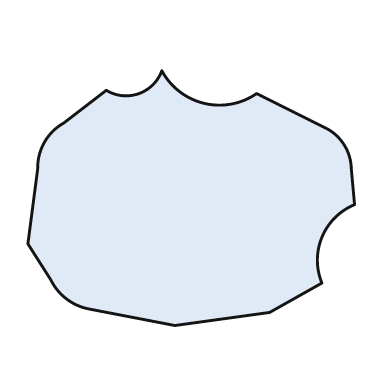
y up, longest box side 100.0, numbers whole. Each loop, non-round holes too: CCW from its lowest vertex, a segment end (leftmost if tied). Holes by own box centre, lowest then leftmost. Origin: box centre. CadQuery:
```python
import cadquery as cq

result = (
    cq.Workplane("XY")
    .moveTo(-5.0, -39.0)
    .lineTo(24.0, -35.0)
    .lineTo(40.0, -26.0)
    .threePointArc((40.0, -12.0), (50.0, -2.0))
    .lineTo(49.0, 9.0)
    .threePointArc((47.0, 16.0), (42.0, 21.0))
    .lineTo(20.0, 32.0)
    .threePointArc((4.0, 29.0), (-9.0, 39.0))
    .threePointArc((-16.0, 32.0), (-26.0, 33.0))
    .lineTo(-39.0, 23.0)
    .threePointArc((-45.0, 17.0), (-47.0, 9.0))
    .lineTo(-50.0, -14.0)
    .lineTo(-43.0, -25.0)
    .threePointArc((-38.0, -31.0), (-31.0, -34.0))
    .close()
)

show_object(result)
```